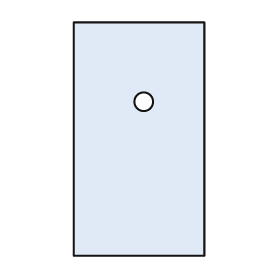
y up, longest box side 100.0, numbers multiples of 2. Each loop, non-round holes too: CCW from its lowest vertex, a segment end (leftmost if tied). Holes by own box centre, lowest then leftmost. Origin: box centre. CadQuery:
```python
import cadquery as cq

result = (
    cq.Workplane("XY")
    .moveTo(-28.0, -50.0)
    .lineTo(28.0, -50.0)
    .lineTo(28.0, 50.0)
    .lineTo(-28.0, 50.0)
    .close()
    .moveTo(2.0, 16.0)
    .circle(4.0)
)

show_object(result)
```